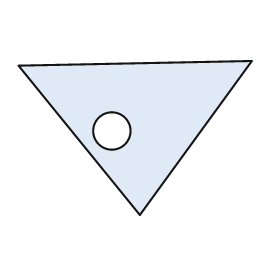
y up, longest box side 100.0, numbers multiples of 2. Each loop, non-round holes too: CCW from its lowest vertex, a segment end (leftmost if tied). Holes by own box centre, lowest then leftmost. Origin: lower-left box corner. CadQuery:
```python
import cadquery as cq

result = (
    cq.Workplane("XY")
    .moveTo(52.0, 0.0)
    .lineTo(100.0, 66.0)
    .lineTo(0.0, 64.0)
    .close()
    .moveTo(40.0, 36.0)
    .circle(8.0)
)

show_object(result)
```